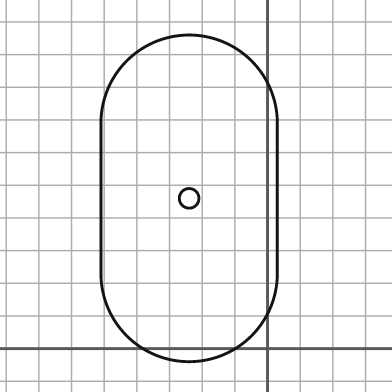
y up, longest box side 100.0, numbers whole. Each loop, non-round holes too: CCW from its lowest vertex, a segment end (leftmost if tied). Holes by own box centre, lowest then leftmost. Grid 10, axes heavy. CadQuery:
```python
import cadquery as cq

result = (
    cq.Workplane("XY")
    .moveTo(-51.0, 23.0)
    .threePointArc((-24.0, -4.0), (3.0, 23.0))
    .lineTo(3.0, 69.0)
    .threePointArc((-24.0, 96.0), (-51.0, 69.0))
    .close()
    .moveTo(-24.0, 46.0)
    .circle(3.0)
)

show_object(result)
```